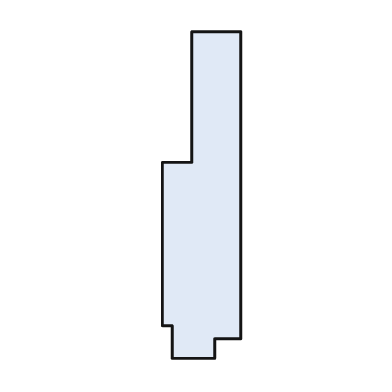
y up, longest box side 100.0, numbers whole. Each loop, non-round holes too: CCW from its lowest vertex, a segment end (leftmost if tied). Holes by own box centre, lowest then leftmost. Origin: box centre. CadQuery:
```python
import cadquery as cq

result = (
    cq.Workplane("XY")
    .moveTo(-9.0, -50.0)
    .lineTo(4.0, -50.0)
    .lineTo(4.0, -44.0)
    .lineTo(12.0, -44.0)
    .lineTo(12.0, 50.0)
    .lineTo(-3.0, 50.0)
    .lineTo(-3.0, 10.0)
    .lineTo(-12.0, 10.0)
    .lineTo(-12.0, -40.0)
    .lineTo(-9.0, -40.0)
    .close()
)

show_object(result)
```